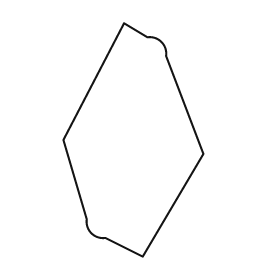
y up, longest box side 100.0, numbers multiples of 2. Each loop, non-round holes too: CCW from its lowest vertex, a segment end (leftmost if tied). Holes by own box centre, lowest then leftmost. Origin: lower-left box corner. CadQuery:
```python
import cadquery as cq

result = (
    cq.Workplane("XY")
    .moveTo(34.0, 0.0)
    .lineTo(60.0, 44.0)
    .lineTo(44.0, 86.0)
    .threePointArc((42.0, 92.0), (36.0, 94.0))
    .lineTo(26.0, 100.0)
    .lineTo(0.0, 50.0)
    .lineTo(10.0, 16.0)
    .threePointArc((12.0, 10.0), (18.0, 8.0))
    .close()
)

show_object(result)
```